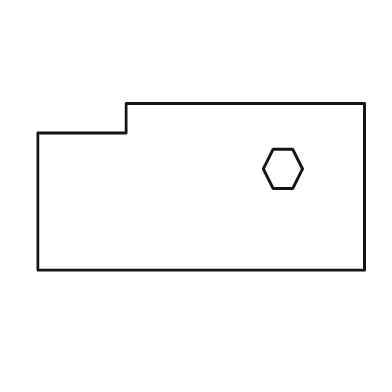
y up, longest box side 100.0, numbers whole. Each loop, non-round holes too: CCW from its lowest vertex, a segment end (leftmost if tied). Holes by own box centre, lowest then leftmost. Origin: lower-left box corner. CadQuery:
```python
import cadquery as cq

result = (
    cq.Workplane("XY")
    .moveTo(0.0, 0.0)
    .lineTo(100.0, 0.0)
    .lineTo(100.0, 51.0)
    .lineTo(27.0, 51.0)
    .lineTo(27.0, 42.0)
    .lineTo(0.0, 42.0)
    .close()
    .moveTo(72.0, 25.0)
    .lineTo(78.0, 25.0)
    .lineTo(81.0, 31.0)
    .lineTo(78.0, 37.0)
    .lineTo(72.0, 37.0)
    .lineTo(69.0, 31.0)
    .close()
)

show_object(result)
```